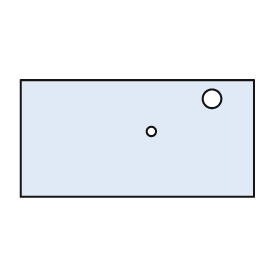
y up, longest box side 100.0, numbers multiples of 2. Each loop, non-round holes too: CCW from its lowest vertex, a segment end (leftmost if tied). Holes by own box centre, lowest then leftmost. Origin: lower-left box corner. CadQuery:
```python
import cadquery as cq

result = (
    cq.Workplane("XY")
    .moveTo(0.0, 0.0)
    .lineTo(100.0, 0.0)
    .lineTo(100.0, 50.0)
    .lineTo(0.0, 50.0)
    .close()
    .moveTo(56.0, 28.0)
    .circle(2.0)
    .moveTo(82.0, 42.0)
    .circle(4.0)
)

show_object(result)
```